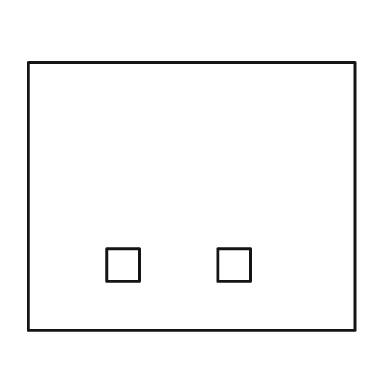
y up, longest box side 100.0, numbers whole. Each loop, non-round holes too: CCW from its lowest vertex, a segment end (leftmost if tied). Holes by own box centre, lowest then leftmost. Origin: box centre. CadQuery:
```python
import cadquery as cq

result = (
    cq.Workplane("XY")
    .moveTo(-50.0, -41.0)
    .lineTo(50.0, -41.0)
    .lineTo(50.0, 41.0)
    .lineTo(-50.0, 41.0)
    .close()
    .moveTo(-26.0, -26.0)
    .lineTo(-16.0, -26.0)
    .lineTo(-16.0, -16.0)
    .lineTo(-26.0, -16.0)
    .close()
    .moveTo(8.0, -26.0)
    .lineTo(18.0, -26.0)
    .lineTo(18.0, -16.0)
    .lineTo(8.0, -16.0)
    .close()
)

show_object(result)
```